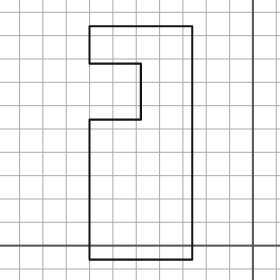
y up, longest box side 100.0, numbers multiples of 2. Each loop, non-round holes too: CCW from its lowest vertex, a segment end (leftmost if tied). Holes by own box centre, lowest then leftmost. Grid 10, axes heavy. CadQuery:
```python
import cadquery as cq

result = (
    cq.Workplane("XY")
    .moveTo(-70.0, -6.0)
    .lineTo(-26.0, -6.0)
    .lineTo(-26.0, 94.0)
    .lineTo(-70.0, 94.0)
    .lineTo(-70.0, 78.0)
    .lineTo(-48.0, 78.0)
    .lineTo(-48.0, 54.0)
    .lineTo(-70.0, 54.0)
    .close()
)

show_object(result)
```